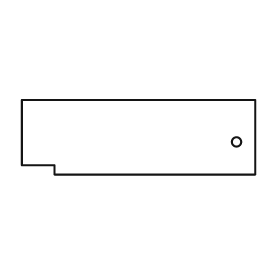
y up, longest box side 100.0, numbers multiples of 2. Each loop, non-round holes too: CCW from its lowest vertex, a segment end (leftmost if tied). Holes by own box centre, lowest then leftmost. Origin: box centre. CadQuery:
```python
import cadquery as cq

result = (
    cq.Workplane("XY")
    .moveTo(-36.0, -16.0)
    .lineTo(50.0, -16.0)
    .lineTo(50.0, 16.0)
    .lineTo(-50.0, 16.0)
    .lineTo(-50.0, -12.0)
    .lineTo(-36.0, -12.0)
    .close()
    .moveTo(42.0, -2.0)
    .circle(2.0)
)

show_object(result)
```